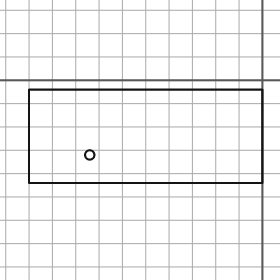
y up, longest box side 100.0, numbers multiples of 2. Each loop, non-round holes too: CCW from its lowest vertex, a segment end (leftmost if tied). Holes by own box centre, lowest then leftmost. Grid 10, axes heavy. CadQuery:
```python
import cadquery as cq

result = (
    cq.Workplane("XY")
    .moveTo(-100.0, -44.0)
    .lineTo(0.0, -44.0)
    .lineTo(0.0, -4.0)
    .lineTo(-100.0, -4.0)
    .close()
    .moveTo(-74.0, -32.0)
    .circle(2.0)
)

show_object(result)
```